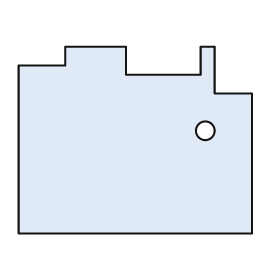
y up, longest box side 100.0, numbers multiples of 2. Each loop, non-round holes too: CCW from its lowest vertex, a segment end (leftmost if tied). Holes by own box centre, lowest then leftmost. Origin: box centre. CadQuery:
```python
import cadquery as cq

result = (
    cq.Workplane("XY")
    .moveTo(-50.0, -40.0)
    .lineTo(50.0, -40.0)
    .lineTo(50.0, 20.0)
    .lineTo(34.0, 20.0)
    .lineTo(34.0, 40.0)
    .lineTo(28.0, 40.0)
    .lineTo(28.0, 28.0)
    .lineTo(-4.0, 28.0)
    .lineTo(-4.0, 40.0)
    .lineTo(-30.0, 40.0)
    .lineTo(-30.0, 32.0)
    .lineTo(-50.0, 32.0)
    .close()
    .moveTo(30.0, 4.0)
    .circle(4.0)
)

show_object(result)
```